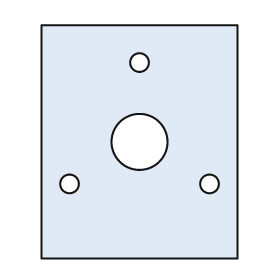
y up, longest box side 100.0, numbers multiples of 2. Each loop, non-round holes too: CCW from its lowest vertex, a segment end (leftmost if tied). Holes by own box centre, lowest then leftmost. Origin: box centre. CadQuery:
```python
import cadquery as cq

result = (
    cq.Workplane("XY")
    .moveTo(-42.0, -50.0)
    .lineTo(42.0, -50.0)
    .lineTo(42.0, 50.0)
    .lineTo(-42.0, 50.0)
    .close()
    .moveTo(-30.0, -18.0)
    .circle(4.0)
    .moveTo(30.0, -18.0)
    .circle(4.0)
    .moveTo(0.0, 0.0)
    .circle(12.0)
    .moveTo(0.0, 34.0)
    .circle(4.0)
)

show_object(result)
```